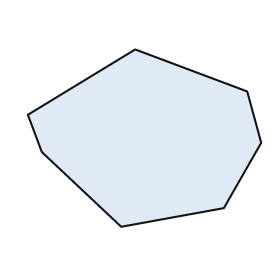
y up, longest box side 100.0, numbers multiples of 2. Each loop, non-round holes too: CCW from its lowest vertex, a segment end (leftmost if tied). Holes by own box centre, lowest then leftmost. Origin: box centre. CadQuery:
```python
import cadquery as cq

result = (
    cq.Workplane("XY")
    .moveTo(-10.0, -38.0)
    .lineTo(34.0, -30.0)
    .lineTo(50.0, -2.0)
    .lineTo(44.0, 20.0)
    .lineTo(-4.0, 38.0)
    .lineTo(-50.0, 10.0)
    .lineTo(-44.0, -6.0)
    .close()
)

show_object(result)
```